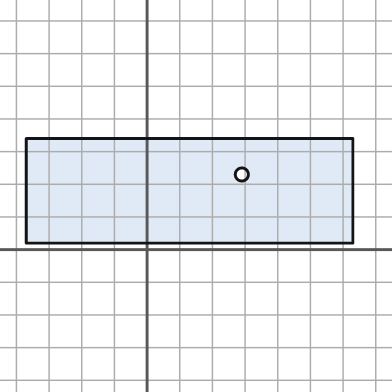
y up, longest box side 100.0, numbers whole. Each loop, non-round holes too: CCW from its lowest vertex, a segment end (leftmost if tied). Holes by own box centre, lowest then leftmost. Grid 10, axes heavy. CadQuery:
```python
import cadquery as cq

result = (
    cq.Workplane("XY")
    .moveTo(-37.0, 2.0)
    .lineTo(63.0, 2.0)
    .lineTo(63.0, 34.0)
    .lineTo(-37.0, 34.0)
    .close()
    .moveTo(29.0, 23.0)
    .circle(2.0)
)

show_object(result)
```